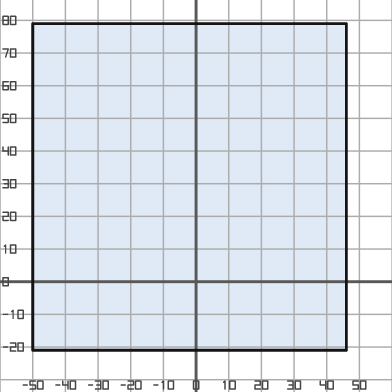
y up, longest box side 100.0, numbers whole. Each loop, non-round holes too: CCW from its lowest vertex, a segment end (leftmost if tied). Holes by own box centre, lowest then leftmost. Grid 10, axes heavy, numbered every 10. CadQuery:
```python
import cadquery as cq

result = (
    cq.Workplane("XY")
    .moveTo(-50.0, -21.0)
    .lineTo(46.0, -21.0)
    .lineTo(46.0, 79.0)
    .lineTo(-50.0, 79.0)
    .close()
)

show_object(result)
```